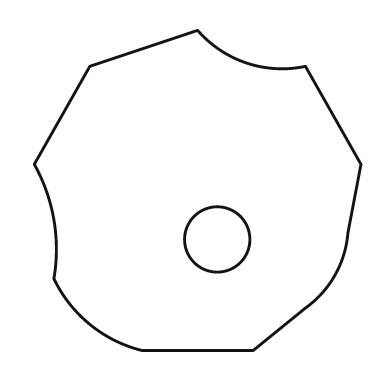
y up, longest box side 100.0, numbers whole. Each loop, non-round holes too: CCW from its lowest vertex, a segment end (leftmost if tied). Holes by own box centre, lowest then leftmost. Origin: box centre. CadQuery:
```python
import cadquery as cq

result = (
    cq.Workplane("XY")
    .moveTo(-17.0, -49.0)
    .lineTo(17.0, -49.0)
    .lineTo(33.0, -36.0)
    .threePointArc((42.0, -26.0), (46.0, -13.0))
    .lineTo(50.0, 8.0)
    .lineTo(33.0, 38.0)
    .threePointArc((15.0, 39.0), (0.0, 49.0))
    .lineTo(-33.0, 38.0)
    .lineTo(-50.0, 8.0)
    .threePointArc((-44.0, -9.0), (-44.0, -27.0))
    .threePointArc((-33.0, -41.0), (-17.0, -49.0))
    .close()
    .moveTo(6.0, -15.0)
    .circle(10.0)
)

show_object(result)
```